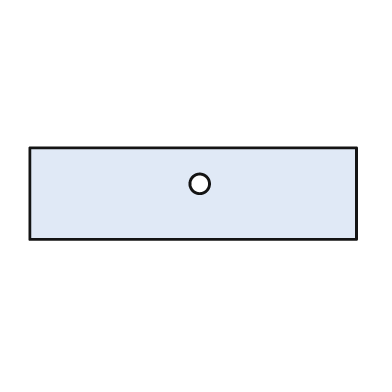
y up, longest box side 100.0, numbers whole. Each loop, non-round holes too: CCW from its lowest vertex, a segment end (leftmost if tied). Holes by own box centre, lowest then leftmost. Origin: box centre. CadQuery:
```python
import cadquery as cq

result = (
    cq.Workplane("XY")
    .moveTo(-50.0, -14.0)
    .lineTo(50.0, -14.0)
    .lineTo(50.0, 14.0)
    .lineTo(-50.0, 14.0)
    .close()
    .moveTo(2.0, 3.0)
    .circle(3.0)
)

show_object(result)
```